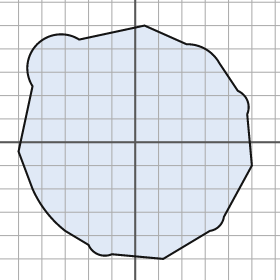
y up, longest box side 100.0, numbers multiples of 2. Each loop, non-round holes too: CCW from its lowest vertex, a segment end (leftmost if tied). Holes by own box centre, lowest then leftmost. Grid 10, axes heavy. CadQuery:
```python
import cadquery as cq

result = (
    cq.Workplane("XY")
    .moveTo(12.0, -50.0)
    .lineTo(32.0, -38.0)
    .threePointArc((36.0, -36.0), (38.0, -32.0))
    .lineTo(50.0, -10.0)
    .lineTo(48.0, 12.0)
    .threePointArc((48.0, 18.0), (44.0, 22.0))
    .lineTo(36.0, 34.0)
    .threePointArc((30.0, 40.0), (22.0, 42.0))
    .lineTo(4.0, 50.0)
    .lineTo(-24.0, 44.0)
    .threePointArc((-42.0, 42.0), (-44.0, 24.0))
    .lineTo(-50.0, -4.0)
    .lineTo(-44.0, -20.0)
    .threePointArc((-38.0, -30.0), (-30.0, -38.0))
    .lineTo(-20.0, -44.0)
    .threePointArc((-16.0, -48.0), (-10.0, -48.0))
    .close()
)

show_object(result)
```